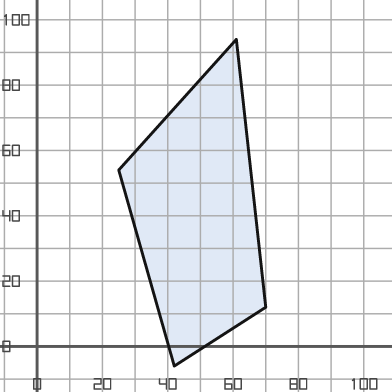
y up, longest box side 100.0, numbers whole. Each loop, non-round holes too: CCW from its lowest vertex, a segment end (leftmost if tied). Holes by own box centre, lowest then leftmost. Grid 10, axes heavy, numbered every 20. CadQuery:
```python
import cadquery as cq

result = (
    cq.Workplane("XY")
    .moveTo(42.0, -6.0)
    .lineTo(70.0, 12.0)
    .lineTo(61.0, 94.0)
    .lineTo(25.0, 54.0)
    .close()
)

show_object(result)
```